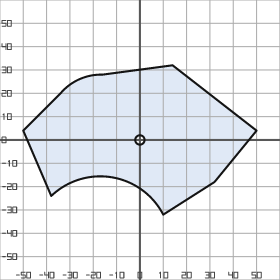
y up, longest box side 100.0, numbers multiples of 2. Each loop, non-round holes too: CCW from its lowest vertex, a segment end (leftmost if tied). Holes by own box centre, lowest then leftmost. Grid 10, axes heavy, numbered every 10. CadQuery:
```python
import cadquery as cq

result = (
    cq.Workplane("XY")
    .moveTo(10.0, -32.0)
    .lineTo(32.0, -18.0)
    .lineTo(50.0, 4.0)
    .lineTo(14.0, 32.0)
    .lineTo(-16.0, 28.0)
    .threePointArc((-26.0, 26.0), (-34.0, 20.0))
    .lineTo(-50.0, 4.0)
    .lineTo(-38.0, -24.0)
    .threePointArc((-12.0, -16.0), (10.0, -32.0))
    .close()
    .moveTo(0.0, 0.0)
    .circle(2.0)
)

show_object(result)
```